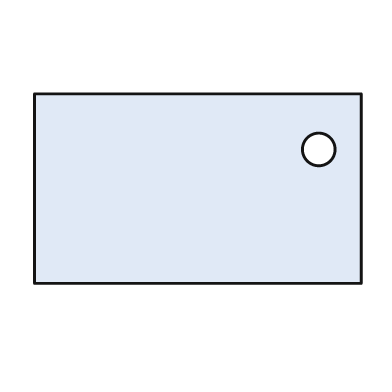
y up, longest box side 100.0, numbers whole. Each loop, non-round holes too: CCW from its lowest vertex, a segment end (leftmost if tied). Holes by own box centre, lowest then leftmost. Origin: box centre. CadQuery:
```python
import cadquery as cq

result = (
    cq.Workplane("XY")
    .moveTo(-50.0, -29.0)
    .lineTo(50.0, -29.0)
    .lineTo(50.0, 29.0)
    .lineTo(-50.0, 29.0)
    .close()
    .moveTo(37.0, 12.0)
    .circle(5.0)
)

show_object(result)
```